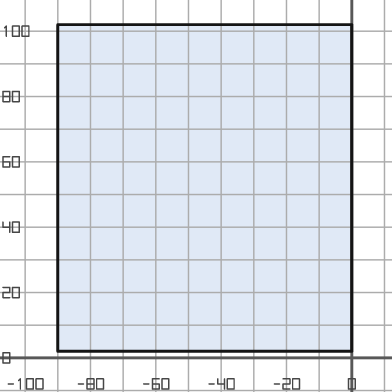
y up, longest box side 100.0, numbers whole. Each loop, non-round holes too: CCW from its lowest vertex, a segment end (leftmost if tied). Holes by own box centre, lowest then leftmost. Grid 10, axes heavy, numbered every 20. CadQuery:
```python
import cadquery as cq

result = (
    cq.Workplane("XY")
    .moveTo(-90.0, 2.0)
    .lineTo(0.0, 2.0)
    .lineTo(0.0, 102.0)
    .lineTo(-90.0, 102.0)
    .close()
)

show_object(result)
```